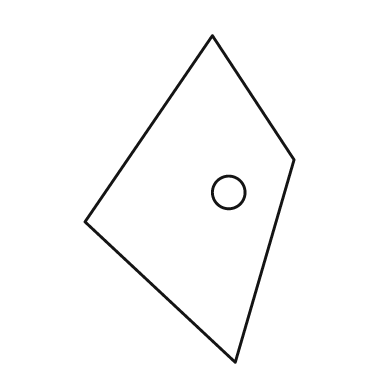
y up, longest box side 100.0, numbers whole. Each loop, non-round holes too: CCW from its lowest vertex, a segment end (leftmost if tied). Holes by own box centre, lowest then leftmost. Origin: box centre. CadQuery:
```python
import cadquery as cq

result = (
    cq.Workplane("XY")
    .moveTo(14.0, -50.0)
    .lineTo(32.0, 12.0)
    .lineTo(7.0, 50.0)
    .lineTo(-32.0, -7.0)
    .close()
    .moveTo(12.0, 2.0)
    .circle(5.0)
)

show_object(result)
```